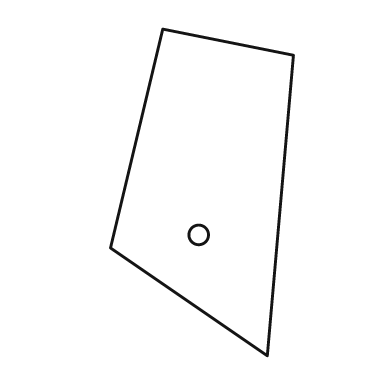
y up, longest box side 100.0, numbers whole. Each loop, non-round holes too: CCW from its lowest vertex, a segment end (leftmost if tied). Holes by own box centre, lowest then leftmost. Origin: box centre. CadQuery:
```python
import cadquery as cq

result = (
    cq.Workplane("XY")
    .moveTo(20.0, -50.0)
    .lineTo(28.0, 42.0)
    .lineTo(-12.0, 50.0)
    .lineTo(-28.0, -17.0)
    .close()
    .moveTo(-1.0, -13.0)
    .circle(3.0)
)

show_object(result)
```